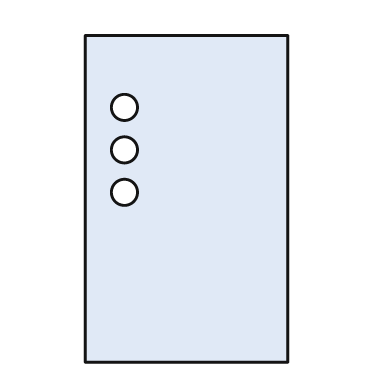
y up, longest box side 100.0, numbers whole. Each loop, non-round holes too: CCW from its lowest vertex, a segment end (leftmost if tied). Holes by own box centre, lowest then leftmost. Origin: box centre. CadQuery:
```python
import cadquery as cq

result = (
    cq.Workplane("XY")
    .moveTo(-31.0, -50.0)
    .lineTo(31.0, -50.0)
    .lineTo(31.0, 50.0)
    .lineTo(-31.0, 50.0)
    .close()
    .moveTo(-19.0, 2.0)
    .circle(4.0)
    .moveTo(-19.0, 15.0)
    .circle(4.0)
    .moveTo(-19.0, 28.0)
    .circle(4.0)
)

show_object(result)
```